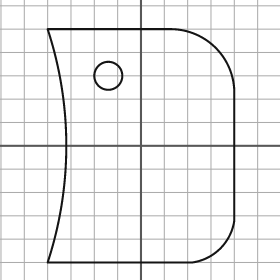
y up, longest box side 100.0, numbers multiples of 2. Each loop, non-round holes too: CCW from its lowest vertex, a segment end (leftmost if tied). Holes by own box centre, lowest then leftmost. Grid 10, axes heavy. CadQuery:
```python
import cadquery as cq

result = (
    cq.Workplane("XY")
    .moveTo(-40.0, -50.0)
    .lineTo(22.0, -50.0)
    .threePointArc((34.0, -44.0), (40.0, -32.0))
    .lineTo(40.0, 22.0)
    .threePointArc((32.0, 42.0), (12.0, 50.0))
    .lineTo(-40.0, 50.0)
    .threePointArc((-32.0, 0.0), (-40.0, -50.0))
    .close()
    .moveTo(-14.0, 30.0)
    .circle(6.0)
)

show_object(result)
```